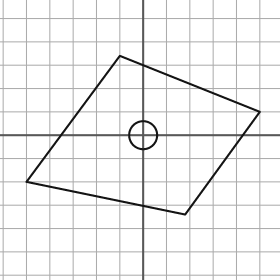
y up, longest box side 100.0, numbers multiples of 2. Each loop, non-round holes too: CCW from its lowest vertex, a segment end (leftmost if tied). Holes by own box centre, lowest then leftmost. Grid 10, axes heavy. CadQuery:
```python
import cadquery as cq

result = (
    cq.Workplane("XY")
    .moveTo(18.0, -34.0)
    .lineTo(50.0, 10.0)
    .lineTo(-10.0, 34.0)
    .lineTo(-50.0, -20.0)
    .close()
    .moveTo(0.0, 0.0)
    .circle(6.0)
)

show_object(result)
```